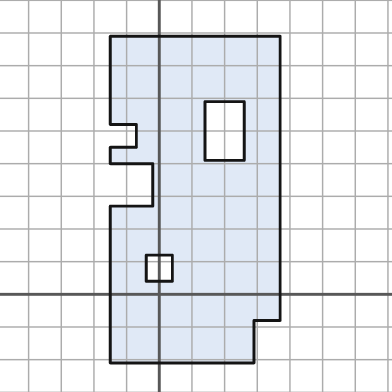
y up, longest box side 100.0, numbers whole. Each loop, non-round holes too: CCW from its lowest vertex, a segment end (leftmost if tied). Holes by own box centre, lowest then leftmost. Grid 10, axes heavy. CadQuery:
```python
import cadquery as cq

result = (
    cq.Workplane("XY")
    .moveTo(-15.0, -21.0)
    .lineTo(29.0, -21.0)
    .lineTo(29.0, -8.0)
    .lineTo(37.0, -8.0)
    .lineTo(37.0, 79.0)
    .lineTo(-15.0, 79.0)
    .lineTo(-15.0, 52.0)
    .lineTo(-7.0, 52.0)
    .lineTo(-7.0, 45.0)
    .lineTo(-15.0, 45.0)
    .lineTo(-15.0, 40.0)
    .lineTo(-2.0, 40.0)
    .lineTo(-2.0, 27.0)
    .lineTo(-15.0, 27.0)
    .close()
    .moveTo(-4.0, 4.0)
    .lineTo(4.0, 4.0)
    .lineTo(4.0, 12.0)
    .lineTo(-4.0, 12.0)
    .close()
    .moveTo(14.0, 41.0)
    .lineTo(26.0, 41.0)
    .lineTo(26.0, 59.0)
    .lineTo(14.0, 59.0)
    .close()
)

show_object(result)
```